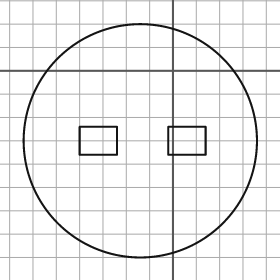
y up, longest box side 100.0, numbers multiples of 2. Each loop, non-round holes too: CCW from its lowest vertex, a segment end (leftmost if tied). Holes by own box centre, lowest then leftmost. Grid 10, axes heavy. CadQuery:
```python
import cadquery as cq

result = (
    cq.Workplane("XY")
    .moveTo(-14.0, -30.0)
    .circle(50.0)
    .moveTo(-40.0, -36.0)
    .lineTo(-24.0, -36.0)
    .lineTo(-24.0, -24.0)
    .lineTo(-40.0, -24.0)
    .close()
    .moveTo(-2.0, -36.0)
    .lineTo(14.0, -36.0)
    .lineTo(14.0, -24.0)
    .lineTo(-2.0, -24.0)
    .close()
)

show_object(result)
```